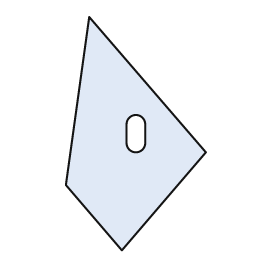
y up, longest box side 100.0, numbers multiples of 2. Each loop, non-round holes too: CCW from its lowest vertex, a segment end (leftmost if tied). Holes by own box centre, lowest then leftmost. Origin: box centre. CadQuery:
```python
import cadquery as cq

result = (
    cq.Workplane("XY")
    .moveTo(-6.0, -50.0)
    .lineTo(30.0, -8.0)
    .lineTo(-20.0, 50.0)
    .lineTo(-30.0, -22.0)
    .close()
    .moveTo(-4.0, -4.0)
    .threePointArc((0.0, -8.0), (4.0, -4.0))
    .lineTo(4.0, 4.0)
    .threePointArc((0.0, 8.0), (-4.0, 4.0))
    .close()
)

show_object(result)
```